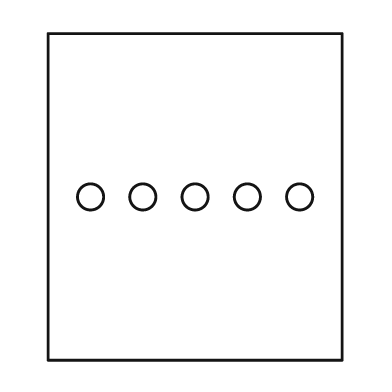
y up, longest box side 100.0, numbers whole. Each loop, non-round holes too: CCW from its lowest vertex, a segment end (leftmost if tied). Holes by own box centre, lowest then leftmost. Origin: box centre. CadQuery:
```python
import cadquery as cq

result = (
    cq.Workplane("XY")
    .moveTo(-45.0, -50.0)
    .lineTo(45.0, -50.0)
    .lineTo(45.0, 50.0)
    .lineTo(-45.0, 50.0)
    .close()
    .moveTo(-32.0, 0.0)
    .circle(4.0)
    .moveTo(-16.0, 0.0)
    .circle(4.0)
    .moveTo(0.0, 0.0)
    .circle(4.0)
    .moveTo(16.0, 0.0)
    .circle(4.0)
    .moveTo(32.0, 0.0)
    .circle(4.0)
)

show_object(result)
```